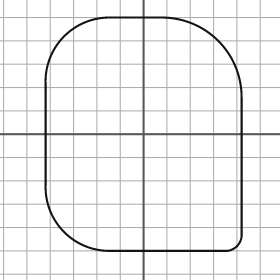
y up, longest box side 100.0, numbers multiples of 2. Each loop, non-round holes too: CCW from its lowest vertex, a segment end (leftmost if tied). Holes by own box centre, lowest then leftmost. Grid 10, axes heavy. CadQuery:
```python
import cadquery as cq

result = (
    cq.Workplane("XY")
    .moveTo(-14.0, -50.0)
    .lineTo(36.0, -50.0)
    .threePointArc((40.0, -48.0), (42.0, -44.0))
    .lineTo(42.0, 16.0)
    .threePointArc((32.0, 40.0), (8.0, 50.0))
    .lineTo(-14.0, 50.0)
    .threePointArc((-34.0, 42.0), (-42.0, 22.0))
    .lineTo(-42.0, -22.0)
    .threePointArc((-34.0, -42.0), (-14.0, -50.0))
    .close()
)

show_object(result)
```